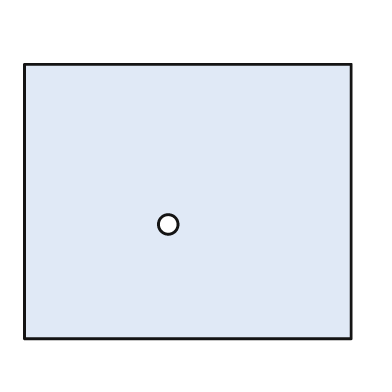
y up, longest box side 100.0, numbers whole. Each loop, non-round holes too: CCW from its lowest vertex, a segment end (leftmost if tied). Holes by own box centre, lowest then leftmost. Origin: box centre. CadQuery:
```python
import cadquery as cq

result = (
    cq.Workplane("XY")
    .moveTo(-50.0, -42.0)
    .lineTo(50.0, -42.0)
    .lineTo(50.0, 42.0)
    .lineTo(-50.0, 42.0)
    .close()
    .moveTo(-6.0, -7.0)
    .circle(3.0)
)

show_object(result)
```